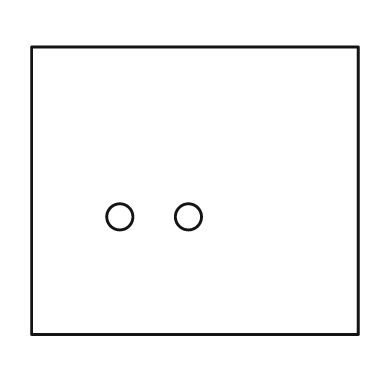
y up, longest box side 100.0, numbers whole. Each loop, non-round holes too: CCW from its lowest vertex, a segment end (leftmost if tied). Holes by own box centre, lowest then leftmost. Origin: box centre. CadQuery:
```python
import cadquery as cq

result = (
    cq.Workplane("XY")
    .moveTo(-50.0, -44.0)
    .lineTo(50.0, -44.0)
    .lineTo(50.0, 44.0)
    .lineTo(-50.0, 44.0)
    .close()
    .moveTo(-23.0, -8.0)
    .circle(4.0)
    .moveTo(-2.0, -8.0)
    .circle(4.0)
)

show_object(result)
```